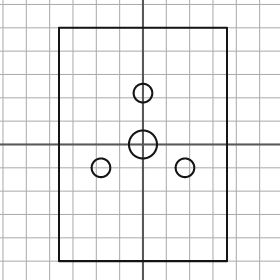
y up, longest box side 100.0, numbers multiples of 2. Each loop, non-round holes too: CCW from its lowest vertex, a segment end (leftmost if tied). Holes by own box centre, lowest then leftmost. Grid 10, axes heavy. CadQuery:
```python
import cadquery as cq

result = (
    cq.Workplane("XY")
    .moveTo(-36.0, -50.0)
    .lineTo(36.0, -50.0)
    .lineTo(36.0, 50.0)
    .lineTo(-36.0, 50.0)
    .close()
    .moveTo(-18.0, -10.0)
    .circle(4.0)
    .moveTo(18.0, -10.0)
    .circle(4.0)
    .moveTo(0.0, 0.0)
    .circle(6.0)
    .moveTo(0.0, 22.0)
    .circle(4.0)
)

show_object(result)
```